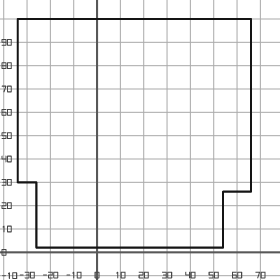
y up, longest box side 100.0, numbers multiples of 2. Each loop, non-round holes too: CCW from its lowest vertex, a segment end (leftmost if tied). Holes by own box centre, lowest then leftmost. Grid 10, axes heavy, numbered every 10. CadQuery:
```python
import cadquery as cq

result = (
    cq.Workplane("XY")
    .moveTo(-26.0, 2.0)
    .lineTo(54.0, 2.0)
    .lineTo(54.0, 26.0)
    .lineTo(66.0, 26.0)
    .lineTo(66.0, 100.0)
    .lineTo(-34.0, 100.0)
    .lineTo(-34.0, 30.0)
    .lineTo(-26.0, 30.0)
    .close()
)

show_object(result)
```